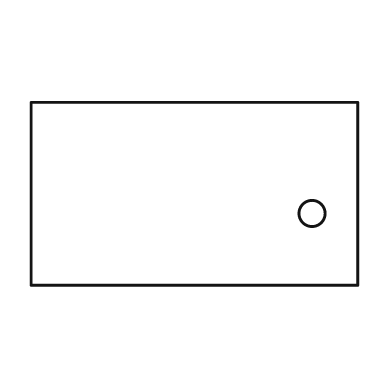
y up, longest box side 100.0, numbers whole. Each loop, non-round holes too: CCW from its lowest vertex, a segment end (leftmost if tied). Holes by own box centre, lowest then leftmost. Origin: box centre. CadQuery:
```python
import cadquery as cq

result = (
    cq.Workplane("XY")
    .moveTo(-50.0, -28.0)
    .lineTo(50.0, -28.0)
    .lineTo(50.0, 28.0)
    .lineTo(-50.0, 28.0)
    .close()
    .moveTo(36.0, -6.0)
    .circle(4.0)
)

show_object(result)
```